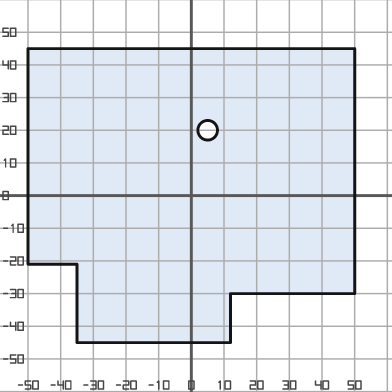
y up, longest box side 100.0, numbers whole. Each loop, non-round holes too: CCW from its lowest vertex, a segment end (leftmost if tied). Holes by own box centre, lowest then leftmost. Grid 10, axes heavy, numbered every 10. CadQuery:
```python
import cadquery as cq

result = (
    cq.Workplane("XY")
    .moveTo(-35.0, -45.0)
    .lineTo(12.0, -45.0)
    .lineTo(12.0, -30.0)
    .lineTo(50.0, -30.0)
    .lineTo(50.0, 45.0)
    .lineTo(-50.0, 45.0)
    .lineTo(-50.0, -21.0)
    .lineTo(-35.0, -21.0)
    .close()
    .moveTo(5.0, 20.0)
    .circle(3.0)
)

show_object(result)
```